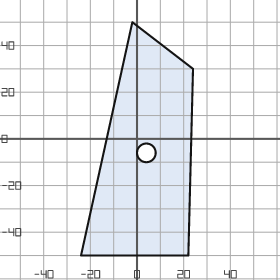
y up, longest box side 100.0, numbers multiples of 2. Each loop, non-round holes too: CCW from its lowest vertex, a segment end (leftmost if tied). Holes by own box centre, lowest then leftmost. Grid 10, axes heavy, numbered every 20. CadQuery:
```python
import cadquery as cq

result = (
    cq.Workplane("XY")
    .moveTo(-24.0, -50.0)
    .lineTo(22.0, -50.0)
    .lineTo(24.0, 30.0)
    .lineTo(-2.0, 50.0)
    .close()
    .moveTo(4.0, -6.0)
    .circle(4.0)
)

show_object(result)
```